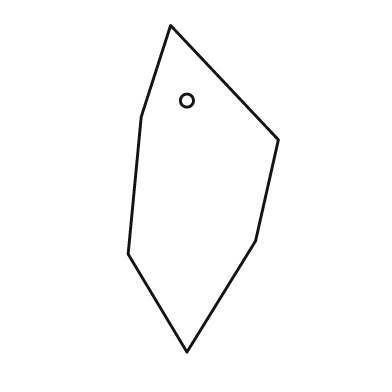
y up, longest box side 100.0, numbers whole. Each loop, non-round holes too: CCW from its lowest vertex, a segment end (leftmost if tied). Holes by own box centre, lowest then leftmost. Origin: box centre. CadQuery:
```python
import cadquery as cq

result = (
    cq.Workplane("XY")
    .moveTo(-5.0, -50.0)
    .lineTo(16.0, -16.0)
    .lineTo(23.0, 15.0)
    .lineTo(-10.0, 50.0)
    .lineTo(-19.0, 22.0)
    .lineTo(-23.0, -20.0)
    .close()
    .moveTo(-5.0, 27.0)
    .circle(2.0)
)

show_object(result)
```